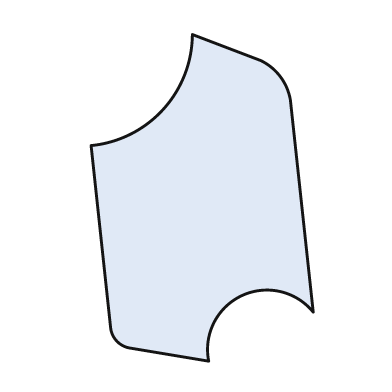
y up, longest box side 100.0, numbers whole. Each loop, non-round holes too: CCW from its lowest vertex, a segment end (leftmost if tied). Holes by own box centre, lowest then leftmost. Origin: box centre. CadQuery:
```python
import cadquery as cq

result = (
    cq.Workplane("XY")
    .moveTo(2.0, -50.0)
    .threePointArc((12.0, -30.0), (34.0, -35.0))
    .lineTo(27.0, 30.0)
    .threePointArc((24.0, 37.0), (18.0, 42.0))
    .lineTo(-3.0, 50.0)
    .threePointArc((-12.0, 27.0), (-34.0, 16.0))
    .lineTo(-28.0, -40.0)
    .threePointArc((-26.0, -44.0), (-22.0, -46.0))
    .close()
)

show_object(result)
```